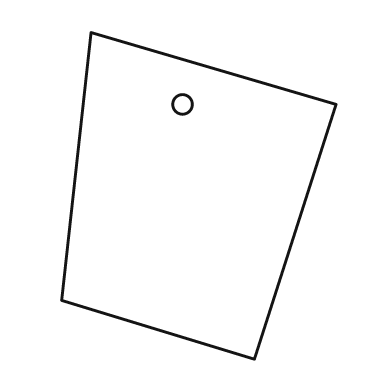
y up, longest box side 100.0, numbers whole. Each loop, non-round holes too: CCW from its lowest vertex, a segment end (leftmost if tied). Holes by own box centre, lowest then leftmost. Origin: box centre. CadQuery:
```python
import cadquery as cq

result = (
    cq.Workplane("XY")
    .moveTo(17.0, -50.0)
    .lineTo(42.0, 28.0)
    .lineTo(-33.0, 50.0)
    .lineTo(-42.0, -32.0)
    .close()
    .moveTo(-5.0, 28.0)
    .circle(3.0)
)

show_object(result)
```